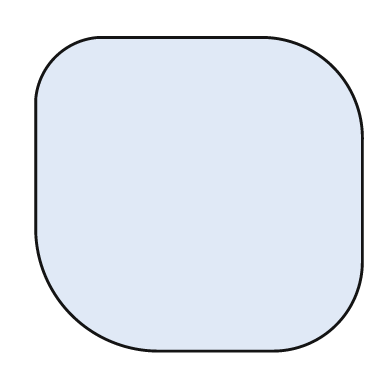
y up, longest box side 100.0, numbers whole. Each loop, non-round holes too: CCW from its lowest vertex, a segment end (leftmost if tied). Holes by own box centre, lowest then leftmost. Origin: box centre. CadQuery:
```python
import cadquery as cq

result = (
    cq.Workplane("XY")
    .moveTo(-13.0, -48.0)
    .lineTo(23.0, -48.0)
    .threePointArc((42.0, -40.0), (50.0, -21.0))
    .lineTo(50.0, 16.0)
    .threePointArc((41.0, 39.0), (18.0, 48.0))
    .lineTo(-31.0, 48.0)
    .threePointArc((-44.0, 42.0), (-50.0, 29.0))
    .lineTo(-50.0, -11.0)
    .threePointArc((-39.0, -37.0), (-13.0, -48.0))
    .close()
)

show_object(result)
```